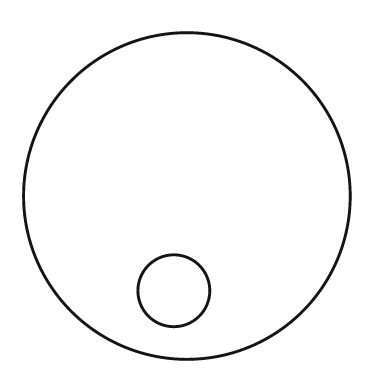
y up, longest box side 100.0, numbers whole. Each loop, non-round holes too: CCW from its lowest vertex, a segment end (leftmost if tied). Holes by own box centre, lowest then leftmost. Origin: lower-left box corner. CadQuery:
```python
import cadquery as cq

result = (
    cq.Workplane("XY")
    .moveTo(50.0, 50.0)
    .circle(50.0)
    .moveTo(46.0, 21.0)
    .circle(11.0)
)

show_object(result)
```